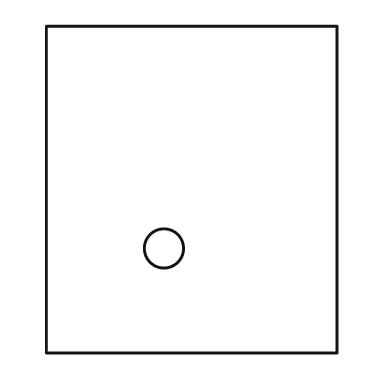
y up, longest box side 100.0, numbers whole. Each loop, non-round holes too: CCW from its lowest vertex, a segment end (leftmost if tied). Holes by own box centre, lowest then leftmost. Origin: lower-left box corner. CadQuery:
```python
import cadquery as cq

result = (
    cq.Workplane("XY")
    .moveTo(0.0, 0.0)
    .lineTo(89.0, 0.0)
    .lineTo(89.0, 100.0)
    .lineTo(0.0, 100.0)
    .close()
    .moveTo(36.0, 32.0)
    .circle(6.0)
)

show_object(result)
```